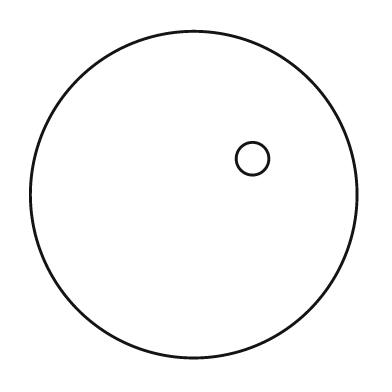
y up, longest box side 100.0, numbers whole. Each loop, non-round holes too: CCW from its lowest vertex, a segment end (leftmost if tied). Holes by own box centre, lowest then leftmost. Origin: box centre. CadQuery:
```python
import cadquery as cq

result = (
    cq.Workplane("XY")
    .moveTo(0.0, 0.0)
    .circle(50.0)
    .moveTo(18.0, 11.0)
    .circle(5.0)
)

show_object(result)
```